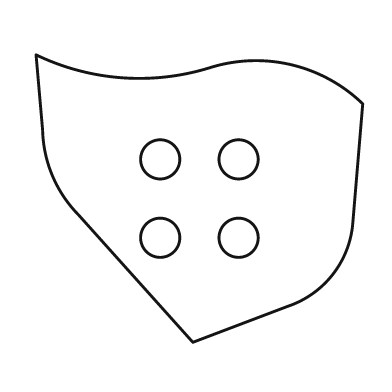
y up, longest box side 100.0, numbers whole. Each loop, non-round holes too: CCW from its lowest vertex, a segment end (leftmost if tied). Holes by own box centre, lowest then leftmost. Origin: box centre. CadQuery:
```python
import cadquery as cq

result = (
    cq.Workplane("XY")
    .moveTo(-2.0, -44.0)
    .lineTo(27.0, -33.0)
    .threePointArc((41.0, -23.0), (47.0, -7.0))
    .lineTo(50.0, 29.0)
    .threePointArc((28.0, 41.0), (3.0, 40.0))
    .threePointArc((-24.0, 37.0), (-50.0, 44.0))
    .lineTo(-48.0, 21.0)
    .threePointArc((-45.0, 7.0), (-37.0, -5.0))
    .close()
    .moveTo(-12.0, -12.0)
    .circle(6.0)
    .moveTo(12.0, -12.0)
    .circle(6.0)
    .moveTo(-12.0, 12.0)
    .circle(6.0)
    .moveTo(12.0, 12.0)
    .circle(6.0)
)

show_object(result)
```